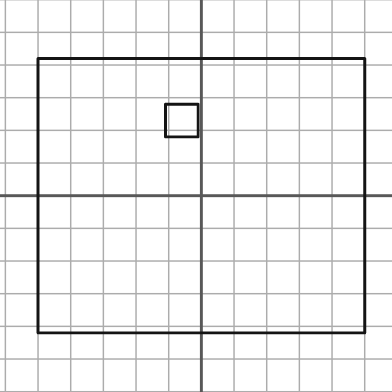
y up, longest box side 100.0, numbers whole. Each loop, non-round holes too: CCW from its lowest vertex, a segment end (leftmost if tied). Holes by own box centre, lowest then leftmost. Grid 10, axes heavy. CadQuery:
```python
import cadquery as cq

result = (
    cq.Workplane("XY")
    .moveTo(-50.0, -42.0)
    .lineTo(50.0, -42.0)
    .lineTo(50.0, 42.0)
    .lineTo(-50.0, 42.0)
    .close()
    .moveTo(-11.0, 18.0)
    .lineTo(-1.0, 18.0)
    .lineTo(-1.0, 28.0)
    .lineTo(-11.0, 28.0)
    .close()
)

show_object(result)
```